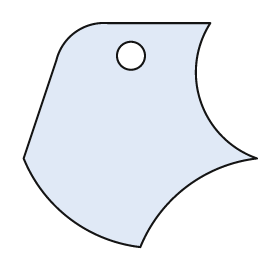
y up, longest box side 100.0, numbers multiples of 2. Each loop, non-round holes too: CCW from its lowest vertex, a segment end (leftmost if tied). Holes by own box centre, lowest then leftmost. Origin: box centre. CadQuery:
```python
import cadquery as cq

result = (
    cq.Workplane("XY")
    .moveTo(0.0, -48.0)
    .threePointArc((20.0, -22.0), (50.0, -10.0))
    .threePointArc((26.0, 14.0), (30.0, 48.0))
    .lineTo(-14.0, 48.0)
    .threePointArc((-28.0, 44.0), (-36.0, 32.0))
    .lineTo(-50.0, -10.0)
    .threePointArc((-30.0, -36.0), (0.0, -48.0))
    .close()
    .moveTo(-4.0, 34.0)
    .circle(6.0)
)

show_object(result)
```